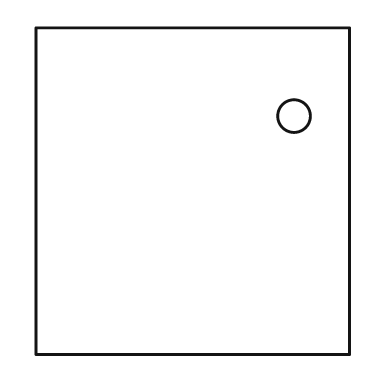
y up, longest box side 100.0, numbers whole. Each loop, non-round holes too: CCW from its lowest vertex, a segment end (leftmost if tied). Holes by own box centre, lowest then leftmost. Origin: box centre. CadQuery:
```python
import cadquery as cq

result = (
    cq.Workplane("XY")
    .moveTo(-48.0, -50.0)
    .lineTo(48.0, -50.0)
    .lineTo(48.0, 50.0)
    .lineTo(-48.0, 50.0)
    .close()
    .moveTo(31.0, 23.0)
    .circle(5.0)
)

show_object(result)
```